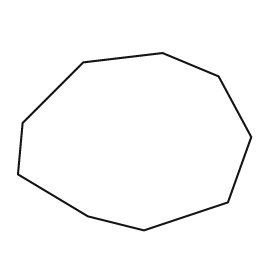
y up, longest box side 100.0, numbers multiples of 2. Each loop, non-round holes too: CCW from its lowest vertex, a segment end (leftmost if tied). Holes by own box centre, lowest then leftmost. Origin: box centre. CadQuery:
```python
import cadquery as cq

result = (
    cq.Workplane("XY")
    .moveTo(4.0, -38.0)
    .lineTo(40.0, -26.0)
    .lineTo(50.0, 2.0)
    .lineTo(36.0, 28.0)
    .lineTo(12.0, 38.0)
    .lineTo(-22.0, 34.0)
    .lineTo(-48.0, 8.0)
    .lineTo(-50.0, -14.0)
    .lineTo(-20.0, -32.0)
    .close()
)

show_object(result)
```